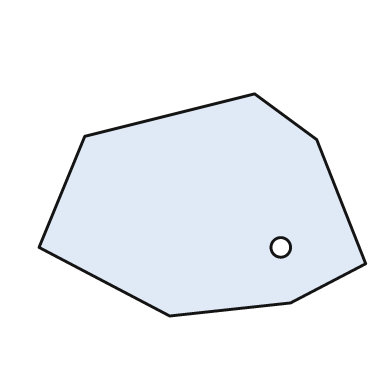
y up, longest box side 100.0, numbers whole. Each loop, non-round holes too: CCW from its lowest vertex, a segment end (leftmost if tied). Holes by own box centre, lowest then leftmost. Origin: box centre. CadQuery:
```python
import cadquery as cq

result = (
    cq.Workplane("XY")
    .moveTo(-10.0, -34.0)
    .lineTo(27.0, -30.0)
    .lineTo(50.0, -18.0)
    .lineTo(35.0, 20.0)
    .lineTo(16.0, 34.0)
    .lineTo(-36.0, 21.0)
    .lineTo(-50.0, -13.0)
    .close()
    .moveTo(24.0, -13.0)
    .circle(3.0)
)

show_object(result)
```